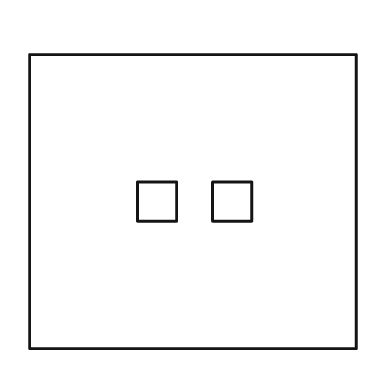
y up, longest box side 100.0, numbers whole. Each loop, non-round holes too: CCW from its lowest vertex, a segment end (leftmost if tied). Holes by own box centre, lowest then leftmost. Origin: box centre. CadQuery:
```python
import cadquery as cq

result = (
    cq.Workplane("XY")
    .moveTo(-50.0, -45.0)
    .lineTo(50.0, -45.0)
    .lineTo(50.0, 45.0)
    .lineTo(-50.0, 45.0)
    .close()
    .moveTo(-17.0, -6.0)
    .lineTo(-5.0, -6.0)
    .lineTo(-5.0, 6.0)
    .lineTo(-17.0, 6.0)
    .close()
    .moveTo(6.0, -6.0)
    .lineTo(18.0, -6.0)
    .lineTo(18.0, 6.0)
    .lineTo(6.0, 6.0)
    .close()
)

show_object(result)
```